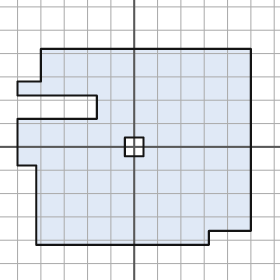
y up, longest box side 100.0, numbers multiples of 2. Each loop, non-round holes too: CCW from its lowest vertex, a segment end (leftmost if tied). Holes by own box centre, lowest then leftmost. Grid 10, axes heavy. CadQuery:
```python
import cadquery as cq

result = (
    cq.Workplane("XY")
    .moveTo(-42.0, -42.0)
    .lineTo(32.0, -42.0)
    .lineTo(32.0, -36.0)
    .lineTo(50.0, -36.0)
    .lineTo(50.0, 42.0)
    .lineTo(-40.0, 42.0)
    .lineTo(-40.0, 28.0)
    .lineTo(-50.0, 28.0)
    .lineTo(-50.0, 22.0)
    .lineTo(-16.0, 22.0)
    .lineTo(-16.0, 12.0)
    .lineTo(-50.0, 12.0)
    .lineTo(-50.0, -8.0)
    .lineTo(-42.0, -8.0)
    .close()
    .moveTo(-4.0, -4.0)
    .lineTo(4.0, -4.0)
    .lineTo(4.0, 4.0)
    .lineTo(-4.0, 4.0)
    .close()
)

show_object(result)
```